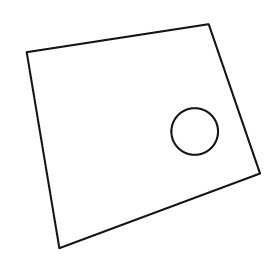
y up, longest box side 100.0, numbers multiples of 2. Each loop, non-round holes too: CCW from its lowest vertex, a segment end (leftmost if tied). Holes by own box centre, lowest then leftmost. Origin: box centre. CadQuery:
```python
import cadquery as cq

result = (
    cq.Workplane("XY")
    .moveTo(-36.0, -48.0)
    .lineTo(50.0, -16.0)
    .lineTo(28.0, 48.0)
    .lineTo(-50.0, 36.0)
    .close()
    .moveTo(22.0, 2.0)
    .circle(10.0)
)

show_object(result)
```